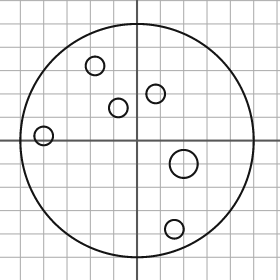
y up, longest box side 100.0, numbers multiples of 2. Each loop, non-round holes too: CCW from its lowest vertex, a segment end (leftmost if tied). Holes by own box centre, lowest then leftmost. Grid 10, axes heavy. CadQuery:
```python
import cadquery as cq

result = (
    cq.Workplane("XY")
    .moveTo(0.0, 0.0)
    .circle(50.0)
    .moveTo(16.0, -38.0)
    .circle(4.0)
    .moveTo(20.0, -10.0)
    .circle(6.0)
    .moveTo(-40.0, 2.0)
    .circle(4.0)
    .moveTo(-8.0, 14.0)
    .circle(4.0)
    .moveTo(8.0, 20.0)
    .circle(4.0)
    .moveTo(-18.0, 32.0)
    .circle(4.0)
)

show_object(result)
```